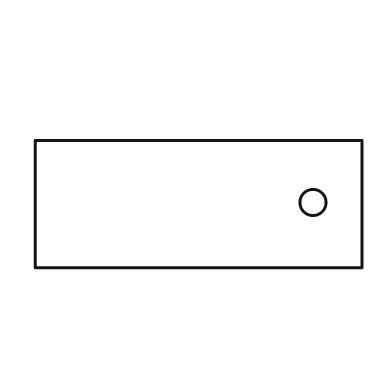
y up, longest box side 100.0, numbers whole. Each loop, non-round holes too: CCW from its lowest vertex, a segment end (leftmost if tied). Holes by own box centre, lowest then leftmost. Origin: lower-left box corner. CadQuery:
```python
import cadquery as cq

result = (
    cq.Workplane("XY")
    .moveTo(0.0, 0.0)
    .lineTo(100.0, 0.0)
    .lineTo(100.0, 39.0)
    .lineTo(0.0, 39.0)
    .close()
    .moveTo(85.0, 20.0)
    .circle(4.0)
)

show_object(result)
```